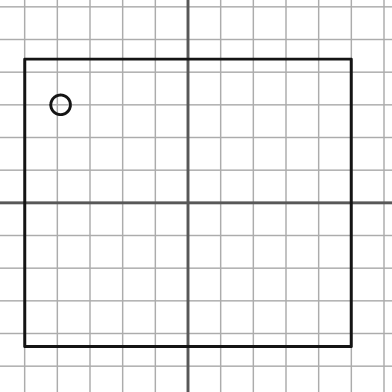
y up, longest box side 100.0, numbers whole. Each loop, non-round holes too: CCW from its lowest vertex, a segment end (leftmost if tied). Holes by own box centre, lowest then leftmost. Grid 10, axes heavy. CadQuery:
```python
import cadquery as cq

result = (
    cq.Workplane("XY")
    .moveTo(-50.0, -44.0)
    .lineTo(50.0, -44.0)
    .lineTo(50.0, 44.0)
    .lineTo(-50.0, 44.0)
    .close()
    .moveTo(-39.0, 30.0)
    .circle(3.0)
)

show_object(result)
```